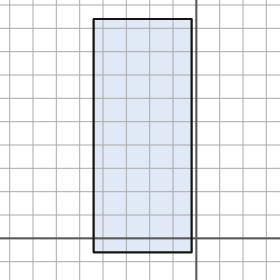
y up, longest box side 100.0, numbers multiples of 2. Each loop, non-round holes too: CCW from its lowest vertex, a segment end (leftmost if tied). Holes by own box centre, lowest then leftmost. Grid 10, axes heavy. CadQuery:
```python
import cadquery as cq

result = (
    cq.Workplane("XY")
    .moveTo(-44.0, -6.0)
    .lineTo(-2.0, -6.0)
    .lineTo(-2.0, 94.0)
    .lineTo(-44.0, 94.0)
    .close()
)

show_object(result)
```